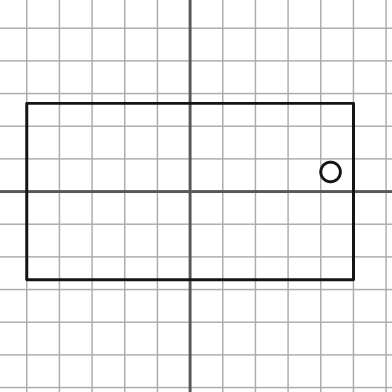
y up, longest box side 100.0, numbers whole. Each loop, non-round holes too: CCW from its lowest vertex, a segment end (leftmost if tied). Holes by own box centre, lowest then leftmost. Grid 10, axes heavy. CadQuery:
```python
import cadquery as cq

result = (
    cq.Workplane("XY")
    .moveTo(-50.0, -27.0)
    .lineTo(50.0, -27.0)
    .lineTo(50.0, 27.0)
    .lineTo(-50.0, 27.0)
    .close()
    .moveTo(43.0, 6.0)
    .circle(3.0)
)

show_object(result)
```